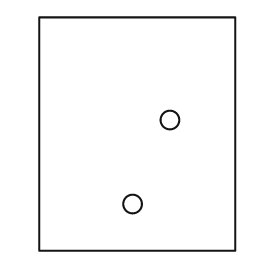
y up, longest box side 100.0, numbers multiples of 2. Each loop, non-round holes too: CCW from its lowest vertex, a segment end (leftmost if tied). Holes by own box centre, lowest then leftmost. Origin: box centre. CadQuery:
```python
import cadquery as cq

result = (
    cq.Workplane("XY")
    .moveTo(-42.0, -50.0)
    .lineTo(42.0, -50.0)
    .lineTo(42.0, 50.0)
    .lineTo(-42.0, 50.0)
    .close()
    .moveTo(-2.0, -30.0)
    .circle(4.0)
    .moveTo(14.0, 6.0)
    .circle(4.0)
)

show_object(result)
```